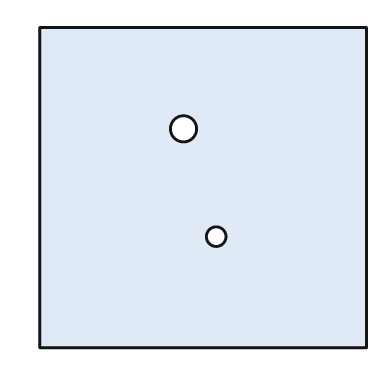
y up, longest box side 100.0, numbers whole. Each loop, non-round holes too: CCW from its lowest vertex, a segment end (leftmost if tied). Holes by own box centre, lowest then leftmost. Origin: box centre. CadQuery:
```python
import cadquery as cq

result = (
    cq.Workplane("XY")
    .moveTo(-50.0, -49.0)
    .lineTo(50.0, -49.0)
    .lineTo(50.0, 49.0)
    .lineTo(-50.0, 49.0)
    .close()
    .moveTo(4.0, -15.0)
    .circle(3.0)
    .moveTo(-6.0, 18.0)
    .circle(4.0)
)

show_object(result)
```